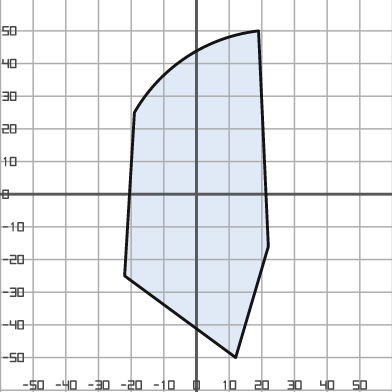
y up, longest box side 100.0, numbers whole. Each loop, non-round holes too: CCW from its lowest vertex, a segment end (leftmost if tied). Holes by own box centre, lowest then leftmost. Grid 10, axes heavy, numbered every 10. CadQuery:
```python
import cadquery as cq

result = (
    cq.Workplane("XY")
    .moveTo(12.0, -50.0)
    .lineTo(22.0, -16.0)
    .lineTo(19.0, 50.0)
    .threePointArc((-3.0, 42.0), (-19.0, 25.0))
    .lineTo(-22.0, -25.0)
    .close()
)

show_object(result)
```